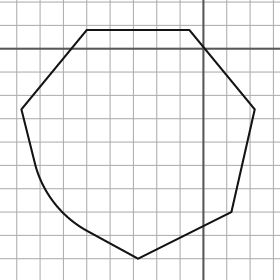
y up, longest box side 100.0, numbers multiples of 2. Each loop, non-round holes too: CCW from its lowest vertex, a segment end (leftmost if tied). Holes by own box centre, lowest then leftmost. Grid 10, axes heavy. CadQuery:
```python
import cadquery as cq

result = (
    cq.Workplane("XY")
    .moveTo(-28.0, -90.0)
    .lineTo(12.0, -70.0)
    .lineTo(22.0, -26.0)
    .lineTo(-6.0, 8.0)
    .lineTo(-50.0, 8.0)
    .lineTo(-78.0, -26.0)
    .lineTo(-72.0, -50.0)
    .threePointArc((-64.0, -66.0), (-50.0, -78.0))
    .close()
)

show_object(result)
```